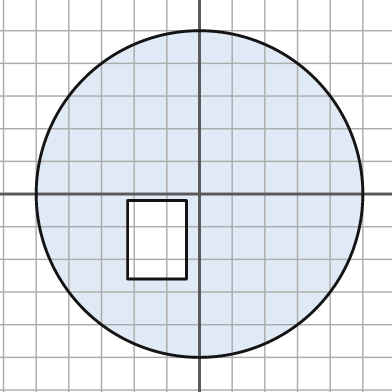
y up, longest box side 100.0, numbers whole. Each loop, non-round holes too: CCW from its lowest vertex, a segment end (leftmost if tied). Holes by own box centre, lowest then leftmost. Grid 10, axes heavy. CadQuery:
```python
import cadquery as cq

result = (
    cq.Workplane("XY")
    .moveTo(0.0, 0.0)
    .circle(50.0)
    .moveTo(-22.0, -26.0)
    .lineTo(-4.0, -26.0)
    .lineTo(-4.0, -2.0)
    .lineTo(-22.0, -2.0)
    .close()
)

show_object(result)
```